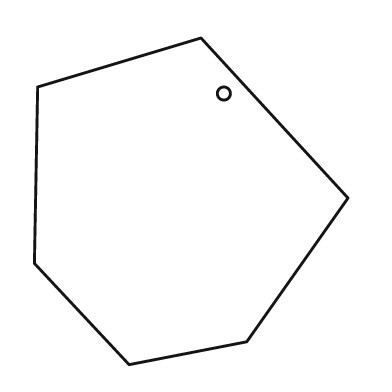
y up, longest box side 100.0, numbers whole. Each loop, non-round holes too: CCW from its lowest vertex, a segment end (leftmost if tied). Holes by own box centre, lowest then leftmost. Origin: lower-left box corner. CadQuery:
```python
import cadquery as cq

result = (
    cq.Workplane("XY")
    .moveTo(29.0, 0.0)
    .lineTo(65.0, 7.0)
    .lineTo(96.0, 51.0)
    .lineTo(51.0, 100.0)
    .lineTo(1.0, 85.0)
    .lineTo(0.0, 31.0)
    .close()
    .moveTo(58.0, 83.0)
    .circle(2.0)
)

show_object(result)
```